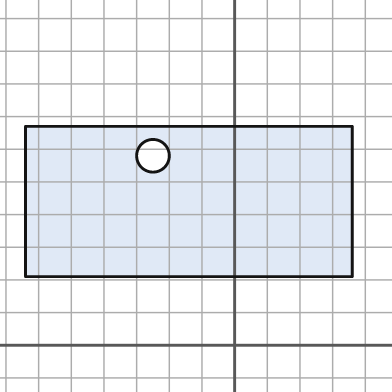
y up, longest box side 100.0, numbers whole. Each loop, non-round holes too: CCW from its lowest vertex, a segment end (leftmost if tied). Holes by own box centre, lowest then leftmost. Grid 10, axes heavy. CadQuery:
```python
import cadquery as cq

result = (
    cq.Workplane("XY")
    .moveTo(-64.0, 21.0)
    .lineTo(36.0, 21.0)
    .lineTo(36.0, 67.0)
    .lineTo(-64.0, 67.0)
    .close()
    .moveTo(-25.0, 58.0)
    .circle(5.0)
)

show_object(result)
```